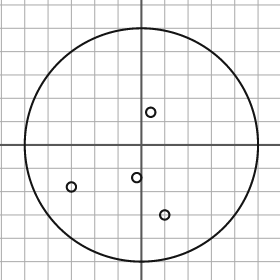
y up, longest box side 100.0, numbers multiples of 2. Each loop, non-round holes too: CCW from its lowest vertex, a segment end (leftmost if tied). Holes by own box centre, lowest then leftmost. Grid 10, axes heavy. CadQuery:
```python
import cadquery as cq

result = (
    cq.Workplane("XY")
    .moveTo(0.0, 0.0)
    .circle(50.0)
    .moveTo(10.0, -30.0)
    .circle(2.0)
    .moveTo(-30.0, -18.0)
    .circle(2.0)
    .moveTo(-2.0, -14.0)
    .circle(2.0)
    .moveTo(4.0, 14.0)
    .circle(2.0)
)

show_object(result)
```